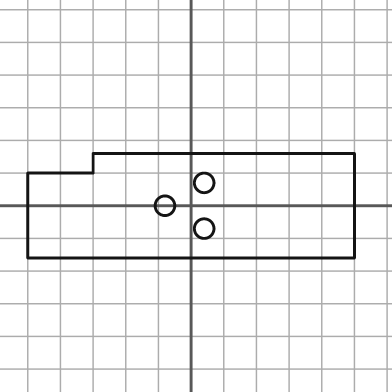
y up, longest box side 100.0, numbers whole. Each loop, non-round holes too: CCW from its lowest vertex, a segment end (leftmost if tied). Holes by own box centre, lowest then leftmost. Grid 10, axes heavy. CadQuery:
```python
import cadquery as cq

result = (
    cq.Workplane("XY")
    .moveTo(-50.0, -16.0)
    .lineTo(50.0, -16.0)
    .lineTo(50.0, 16.0)
    .lineTo(-30.0, 16.0)
    .lineTo(-30.0, 10.0)
    .lineTo(-50.0, 10.0)
    .close()
    .moveTo(4.0, -7.0)
    .circle(3.0)
    .moveTo(-8.0, 0.0)
    .circle(3.0)
    .moveTo(4.0, 7.0)
    .circle(3.0)
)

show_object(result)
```